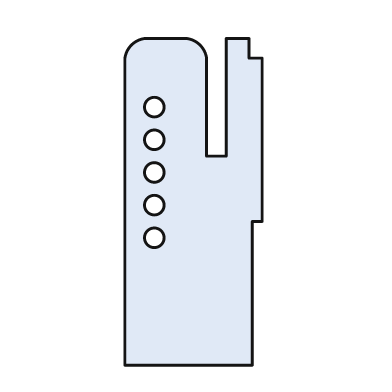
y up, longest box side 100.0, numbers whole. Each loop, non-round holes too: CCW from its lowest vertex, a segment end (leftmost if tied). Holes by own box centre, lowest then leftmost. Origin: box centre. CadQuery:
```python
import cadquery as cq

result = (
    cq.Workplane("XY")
    .moveTo(-21.0, -50.0)
    .lineTo(18.0, -50.0)
    .lineTo(18.0, -6.0)
    .lineTo(21.0, -6.0)
    .lineTo(21.0, 44.0)
    .lineTo(17.0, 44.0)
    .lineTo(17.0, 50.0)
    .lineTo(10.0, 50.0)
    .lineTo(10.0, 14.0)
    .lineTo(4.0, 14.0)
    .lineTo(4.0, 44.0)
    .threePointArc((2.0, 48.0), (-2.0, 50.0))
    .lineTo(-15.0, 50.0)
    .threePointArc((-19.0, 48.0), (-21.0, 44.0))
    .close()
    .moveTo(-12.0, -11.0)
    .circle(3.0)
    .moveTo(-12.0, -1.0)
    .circle(3.0)
    .moveTo(-12.0, 9.0)
    .circle(3.0)
    .moveTo(-12.0, 19.0)
    .circle(3.0)
    .moveTo(-12.0, 29.0)
    .circle(3.0)
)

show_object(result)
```